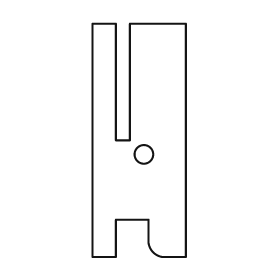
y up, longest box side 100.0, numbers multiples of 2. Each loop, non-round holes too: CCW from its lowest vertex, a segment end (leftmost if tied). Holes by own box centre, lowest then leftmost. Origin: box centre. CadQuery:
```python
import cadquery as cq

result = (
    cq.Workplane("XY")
    .moveTo(-20.0, -50.0)
    .lineTo(-10.0, -50.0)
    .lineTo(-10.0, -34.0)
    .lineTo(4.0, -34.0)
    .lineTo(4.0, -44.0)
    .threePointArc((6.0, -48.0), (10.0, -50.0))
    .lineTo(20.0, -50.0)
    .lineTo(20.0, 50.0)
    .lineTo(-4.0, 50.0)
    .lineTo(-4.0, 0.0)
    .lineTo(-10.0, 0.0)
    .lineTo(-10.0, 50.0)
    .lineTo(-20.0, 50.0)
    .close()
    .moveTo(2.0, -6.0)
    .circle(4.0)
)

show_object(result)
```